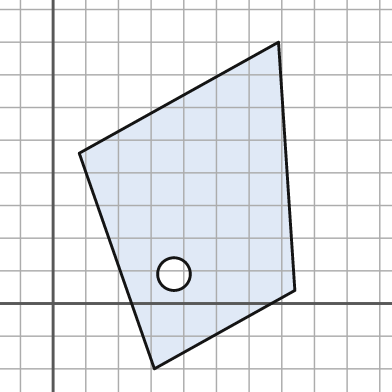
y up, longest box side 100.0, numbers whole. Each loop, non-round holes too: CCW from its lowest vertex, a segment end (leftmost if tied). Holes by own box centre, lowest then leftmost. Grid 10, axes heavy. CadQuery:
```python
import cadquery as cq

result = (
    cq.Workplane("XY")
    .moveTo(31.0, -20.0)
    .lineTo(74.0, 4.0)
    .lineTo(69.0, 80.0)
    .lineTo(8.0, 46.0)
    .close()
    .moveTo(37.0, 9.0)
    .circle(5.0)
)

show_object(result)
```